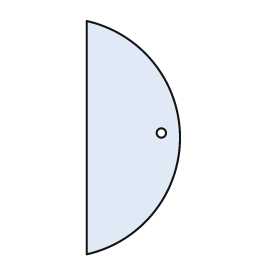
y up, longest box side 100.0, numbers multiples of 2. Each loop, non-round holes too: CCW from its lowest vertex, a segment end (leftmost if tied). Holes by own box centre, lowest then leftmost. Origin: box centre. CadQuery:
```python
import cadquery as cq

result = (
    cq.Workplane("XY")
    .moveTo(-20.0, -50.0)
    .threePointArc((20.0, 0.0), (-20.0, 50.0))
    .close()
    .moveTo(12.0, 2.0)
    .circle(2.0)
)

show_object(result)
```